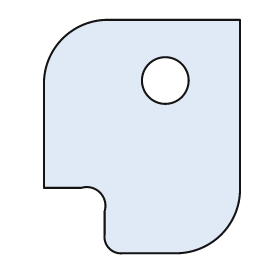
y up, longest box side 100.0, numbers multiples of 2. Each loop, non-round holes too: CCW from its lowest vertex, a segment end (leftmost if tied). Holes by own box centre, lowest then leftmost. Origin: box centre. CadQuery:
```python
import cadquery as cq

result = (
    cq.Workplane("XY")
    .moveTo(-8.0, -50.0)
    .lineTo(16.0, -50.0)
    .threePointArc((34.0, -42.0), (42.0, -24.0))
    .lineTo(42.0, 50.0)
    .lineTo(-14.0, 50.0)
    .threePointArc((-34.0, 42.0), (-42.0, 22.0))
    .lineTo(-42.0, -22.0)
    .lineTo(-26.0, -22.0)
    .threePointArc((-18.0, -24.0), (-16.0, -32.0))
    .lineTo(-16.0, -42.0)
    .threePointArc((-14.0, -48.0), (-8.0, -50.0))
    .close()
    .moveTo(10.0, 24.0)
    .circle(10.0)
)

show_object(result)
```